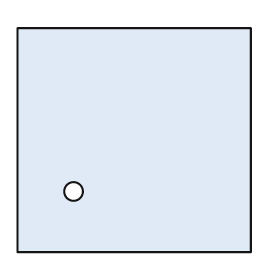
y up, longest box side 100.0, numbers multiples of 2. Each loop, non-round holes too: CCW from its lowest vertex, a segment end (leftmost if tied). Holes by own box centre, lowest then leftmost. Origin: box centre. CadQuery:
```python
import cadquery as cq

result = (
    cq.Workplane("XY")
    .moveTo(-50.0, -48.0)
    .lineTo(50.0, -48.0)
    .lineTo(50.0, 48.0)
    .lineTo(-50.0, 48.0)
    .close()
    .moveTo(-26.0, -22.0)
    .circle(4.0)
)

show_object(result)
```